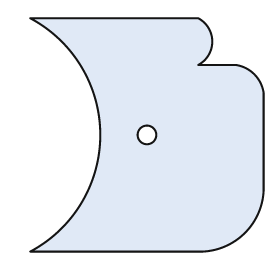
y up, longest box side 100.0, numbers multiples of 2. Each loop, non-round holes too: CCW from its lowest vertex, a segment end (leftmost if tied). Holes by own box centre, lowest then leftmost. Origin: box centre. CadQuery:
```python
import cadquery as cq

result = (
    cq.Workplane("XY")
    .moveTo(-50.0, -50.0)
    .lineTo(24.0, -50.0)
    .threePointArc((42.0, -42.0), (50.0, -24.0))
    .lineTo(50.0, 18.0)
    .threePointArc((46.0, 26.0), (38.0, 30.0))
    .lineTo(22.0, 30.0)
    .threePointArc((28.0, 40.0), (22.0, 50.0))
    .lineTo(-50.0, 50.0)
    .threePointArc((-20.0, 0.0), (-50.0, -50.0))
    .close()
    .moveTo(0.0, 0.0)
    .circle(4.0)
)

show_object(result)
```